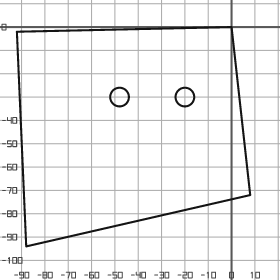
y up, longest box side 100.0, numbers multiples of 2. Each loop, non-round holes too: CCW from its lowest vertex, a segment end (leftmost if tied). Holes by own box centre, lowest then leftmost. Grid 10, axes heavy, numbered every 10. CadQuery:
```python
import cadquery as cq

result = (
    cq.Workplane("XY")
    .moveTo(-88.0, -94.0)
    .lineTo(8.0, -72.0)
    .lineTo(0.0, 0.0)
    .lineTo(-92.0, -2.0)
    .close()
    .moveTo(-48.0, -30.0)
    .circle(4.0)
    .moveTo(-20.0, -30.0)
    .circle(4.0)
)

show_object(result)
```